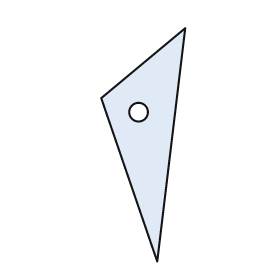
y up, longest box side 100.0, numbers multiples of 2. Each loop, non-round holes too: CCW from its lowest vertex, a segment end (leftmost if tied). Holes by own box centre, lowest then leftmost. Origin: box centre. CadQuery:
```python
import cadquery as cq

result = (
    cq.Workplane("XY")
    .moveTo(6.0, -50.0)
    .lineTo(18.0, 50.0)
    .lineTo(-18.0, 20.0)
    .close()
    .moveTo(-2.0, 14.0)
    .circle(4.0)
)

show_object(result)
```